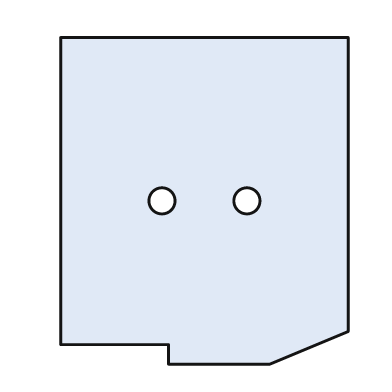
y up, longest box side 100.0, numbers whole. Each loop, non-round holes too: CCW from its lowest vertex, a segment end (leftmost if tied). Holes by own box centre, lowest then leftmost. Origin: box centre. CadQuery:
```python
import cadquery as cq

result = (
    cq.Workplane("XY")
    .moveTo(-11.0, -50.0)
    .lineTo(20.0, -50.0)
    .lineTo(44.0, -40.0)
    .lineTo(44.0, 50.0)
    .lineTo(-44.0, 50.0)
    .lineTo(-44.0, -44.0)
    .lineTo(-11.0, -44.0)
    .close()
    .moveTo(-13.0, 0.0)
    .circle(4.0)
    .moveTo(13.0, 0.0)
    .circle(4.0)
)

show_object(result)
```